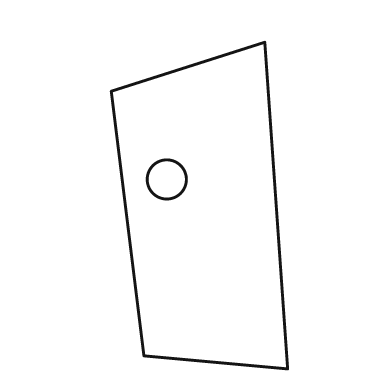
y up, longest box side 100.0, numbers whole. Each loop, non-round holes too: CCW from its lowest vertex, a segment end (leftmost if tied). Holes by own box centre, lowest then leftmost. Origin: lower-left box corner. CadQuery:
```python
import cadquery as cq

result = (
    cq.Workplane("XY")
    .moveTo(54.0, 0.0)
    .lineTo(47.0, 100.0)
    .lineTo(0.0, 85.0)
    .lineTo(10.0, 4.0)
    .close()
    .moveTo(17.0, 58.0)
    .circle(6.0)
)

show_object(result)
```